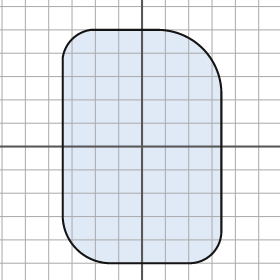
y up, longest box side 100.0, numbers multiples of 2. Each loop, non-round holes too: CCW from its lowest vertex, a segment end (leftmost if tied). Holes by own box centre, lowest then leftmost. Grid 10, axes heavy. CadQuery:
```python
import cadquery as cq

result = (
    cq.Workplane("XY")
    .moveTo(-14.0, -50.0)
    .lineTo(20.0, -50.0)
    .threePointArc((30.0, -46.0), (34.0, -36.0))
    .lineTo(34.0, 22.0)
    .threePointArc((26.0, 42.0), (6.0, 50.0))
    .lineTo(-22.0, 50.0)
    .threePointArc((-30.0, 46.0), (-34.0, 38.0))
    .lineTo(-34.0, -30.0)
    .threePointArc((-28.0, -44.0), (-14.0, -50.0))
    .close()
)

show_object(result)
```